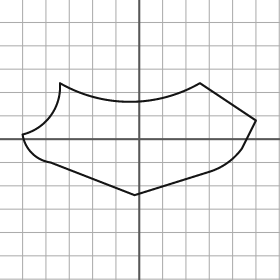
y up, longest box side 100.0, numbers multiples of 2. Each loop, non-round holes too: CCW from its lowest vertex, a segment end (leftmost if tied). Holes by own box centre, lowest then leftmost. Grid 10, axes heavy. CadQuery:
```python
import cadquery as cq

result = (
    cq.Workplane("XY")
    .moveTo(-2.0, -24.0)
    .lineTo(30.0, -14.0)
    .threePointArc((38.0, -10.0), (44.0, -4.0))
    .lineTo(50.0, 8.0)
    .lineTo(26.0, 24.0)
    .threePointArc((-4.0, 16.0), (-34.0, 24.0))
    .threePointArc((-38.0, 10.0), (-50.0, 2.0))
    .threePointArc((-46.0, -6.0), (-38.0, -10.0))
    .close()
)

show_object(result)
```